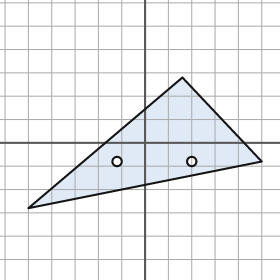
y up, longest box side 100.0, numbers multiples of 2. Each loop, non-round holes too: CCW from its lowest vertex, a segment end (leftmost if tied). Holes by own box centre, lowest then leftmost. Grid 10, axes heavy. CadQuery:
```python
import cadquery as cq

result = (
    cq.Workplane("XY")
    .moveTo(-50.0, -28.0)
    .lineTo(50.0, -8.0)
    .lineTo(16.0, 28.0)
    .close()
    .moveTo(-12.0, -8.0)
    .circle(2.0)
    .moveTo(20.0, -8.0)
    .circle(2.0)
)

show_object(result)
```